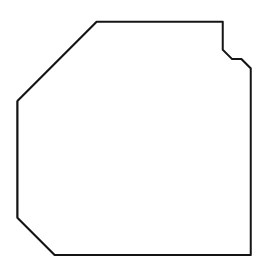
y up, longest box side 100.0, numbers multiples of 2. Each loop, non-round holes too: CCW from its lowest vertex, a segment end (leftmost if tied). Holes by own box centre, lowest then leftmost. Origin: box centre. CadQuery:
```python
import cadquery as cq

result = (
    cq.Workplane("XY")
    .moveTo(-34.0, -50.0)
    .lineTo(50.0, -50.0)
    .lineTo(50.0, 30.0)
    .lineTo(46.0, 34.0)
    .lineTo(42.0, 34.0)
    .lineTo(38.0, 38.0)
    .lineTo(38.0, 50.0)
    .lineTo(-16.0, 50.0)
    .lineTo(-50.0, 16.0)
    .lineTo(-50.0, -34.0)
    .close()
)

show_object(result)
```